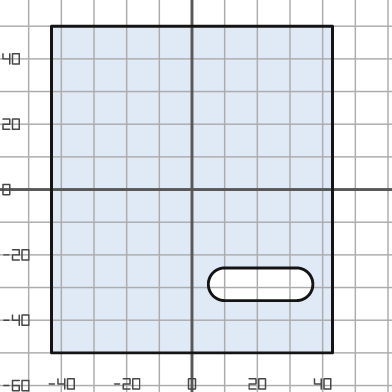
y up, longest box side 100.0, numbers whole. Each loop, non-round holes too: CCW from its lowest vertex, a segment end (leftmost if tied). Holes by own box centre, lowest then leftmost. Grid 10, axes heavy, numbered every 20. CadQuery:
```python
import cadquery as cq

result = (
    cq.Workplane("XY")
    .moveTo(-43.0, -50.0)
    .lineTo(43.0, -50.0)
    .lineTo(43.0, 50.0)
    .lineTo(-43.0, 50.0)
    .close()
    .moveTo(10.0, -34.0)
    .lineTo(32.0, -34.0)
    .threePointArc((37.0, -29.0), (32.0, -24.0))
    .lineTo(10.0, -24.0)
    .threePointArc((5.0, -29.0), (10.0, -34.0))
    .close()
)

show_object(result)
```